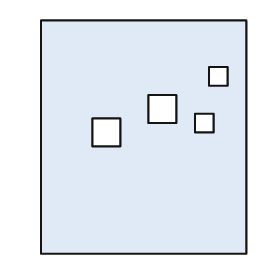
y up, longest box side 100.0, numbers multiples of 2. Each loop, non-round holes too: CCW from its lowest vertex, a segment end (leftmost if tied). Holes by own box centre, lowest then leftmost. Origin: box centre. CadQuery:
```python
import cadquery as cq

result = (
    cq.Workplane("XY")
    .moveTo(-44.0, -50.0)
    .lineTo(44.0, -50.0)
    .lineTo(44.0, 50.0)
    .lineTo(-44.0, 50.0)
    .close()
    .moveTo(-22.0, -4.0)
    .lineTo(-10.0, -4.0)
    .lineTo(-10.0, 8.0)
    .lineTo(-22.0, 8.0)
    .close()
    .moveTo(22.0, 2.0)
    .lineTo(30.0, 2.0)
    .lineTo(30.0, 10.0)
    .lineTo(22.0, 10.0)
    .close()
    .moveTo(2.0, 6.0)
    .lineTo(14.0, 6.0)
    .lineTo(14.0, 18.0)
    .lineTo(2.0, 18.0)
    .close()
    .moveTo(28.0, 22.0)
    .lineTo(36.0, 22.0)
    .lineTo(36.0, 30.0)
    .lineTo(28.0, 30.0)
    .close()
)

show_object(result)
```